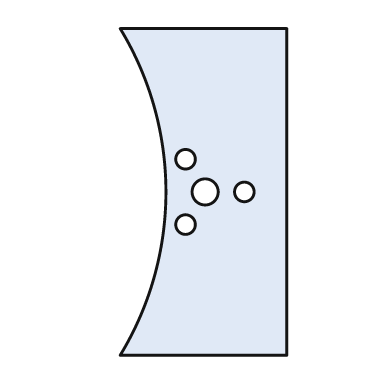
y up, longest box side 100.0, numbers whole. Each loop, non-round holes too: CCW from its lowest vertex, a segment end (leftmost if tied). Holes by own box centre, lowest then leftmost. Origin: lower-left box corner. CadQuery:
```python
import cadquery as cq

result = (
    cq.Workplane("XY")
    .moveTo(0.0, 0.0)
    .lineTo(51.0, 0.0)
    .lineTo(51.0, 100.0)
    .lineTo(0.0, 100.0)
    .threePointArc((14.0, 50.0), (0.0, 0.0))
    .close()
    .moveTo(20.0, 40.0)
    .circle(3.0)
    .moveTo(26.0, 50.0)
    .circle(4.0)
    .moveTo(38.0, 50.0)
    .circle(3.0)
    .moveTo(20.0, 60.0)
    .circle(3.0)
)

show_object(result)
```